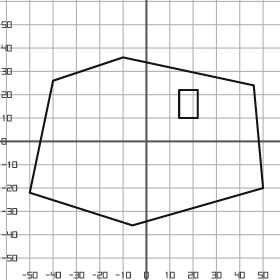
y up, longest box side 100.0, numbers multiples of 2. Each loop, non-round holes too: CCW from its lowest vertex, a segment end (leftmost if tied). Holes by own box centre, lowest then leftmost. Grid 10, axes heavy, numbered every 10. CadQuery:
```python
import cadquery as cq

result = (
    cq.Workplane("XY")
    .moveTo(-6.0, -36.0)
    .lineTo(50.0, -20.0)
    .lineTo(46.0, 24.0)
    .lineTo(-10.0, 36.0)
    .lineTo(-40.0, 26.0)
    .lineTo(-50.0, -22.0)
    .close()
    .moveTo(14.0, 10.0)
    .lineTo(22.0, 10.0)
    .lineTo(22.0, 22.0)
    .lineTo(14.0, 22.0)
    .close()
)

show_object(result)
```